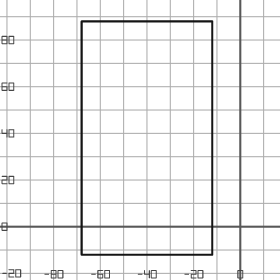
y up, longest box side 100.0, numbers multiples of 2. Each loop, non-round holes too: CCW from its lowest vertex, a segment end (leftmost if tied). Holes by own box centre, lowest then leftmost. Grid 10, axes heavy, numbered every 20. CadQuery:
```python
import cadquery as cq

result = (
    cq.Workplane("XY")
    .moveTo(-68.0, -12.0)
    .lineTo(-12.0, -12.0)
    .lineTo(-12.0, 88.0)
    .lineTo(-68.0, 88.0)
    .close()
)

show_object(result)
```